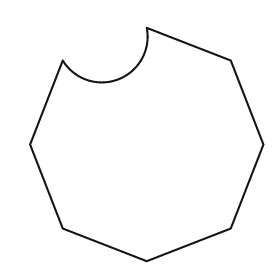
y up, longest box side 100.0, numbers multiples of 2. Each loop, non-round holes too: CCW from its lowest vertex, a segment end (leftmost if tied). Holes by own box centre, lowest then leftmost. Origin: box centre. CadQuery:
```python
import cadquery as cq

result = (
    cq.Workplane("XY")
    .moveTo(0.0, -50.0)
    .lineTo(36.0, -36.0)
    .lineTo(50.0, 0.0)
    .lineTo(36.0, 36.0)
    .lineTo(0.0, 50.0)
    .threePointArc((-12.0, 28.0), (-36.0, 36.0))
    .lineTo(-50.0, 0.0)
    .lineTo(-36.0, -36.0)
    .close()
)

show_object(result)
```